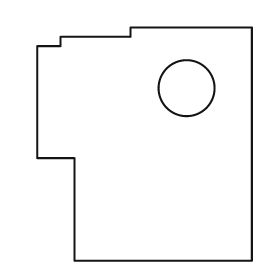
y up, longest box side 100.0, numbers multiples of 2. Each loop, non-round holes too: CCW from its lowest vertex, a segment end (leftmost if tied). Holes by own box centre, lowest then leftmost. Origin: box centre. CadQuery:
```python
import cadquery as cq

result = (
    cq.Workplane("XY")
    .moveTo(-30.0, -50.0)
    .lineTo(46.0, -50.0)
    .lineTo(46.0, 50.0)
    .lineTo(-6.0, 50.0)
    .lineTo(-6.0, 46.0)
    .lineTo(-36.0, 46.0)
    .lineTo(-36.0, 42.0)
    .lineTo(-46.0, 42.0)
    .lineTo(-46.0, -6.0)
    .lineTo(-30.0, -6.0)
    .close()
    .moveTo(18.0, 24.0)
    .circle(12.0)
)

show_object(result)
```